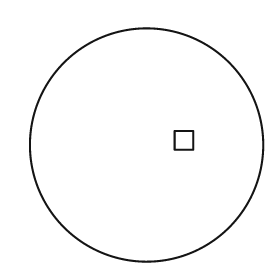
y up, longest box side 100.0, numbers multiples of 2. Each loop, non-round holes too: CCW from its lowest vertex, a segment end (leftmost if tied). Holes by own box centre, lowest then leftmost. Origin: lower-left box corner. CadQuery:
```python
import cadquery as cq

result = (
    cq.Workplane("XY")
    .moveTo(50.0, 50.0)
    .circle(50.0)
    .moveTo(62.0, 48.0)
    .lineTo(70.0, 48.0)
    .lineTo(70.0, 56.0)
    .lineTo(62.0, 56.0)
    .close()
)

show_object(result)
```